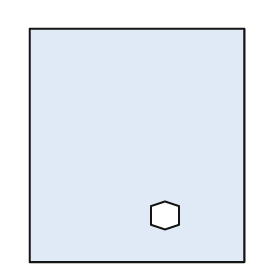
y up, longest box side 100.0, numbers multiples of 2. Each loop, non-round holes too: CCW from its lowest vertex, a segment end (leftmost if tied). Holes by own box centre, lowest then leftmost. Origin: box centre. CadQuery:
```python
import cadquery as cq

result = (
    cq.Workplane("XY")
    .moveTo(-46.0, -50.0)
    .lineTo(46.0, -50.0)
    .lineTo(46.0, 50.0)
    .lineTo(-46.0, 50.0)
    .close()
    .moveTo(12.0, -36.0)
    .lineTo(18.0, -34.0)
    .lineTo(18.0, -26.0)
    .lineTo(12.0, -24.0)
    .lineTo(6.0, -26.0)
    .lineTo(6.0, -34.0)
    .close()
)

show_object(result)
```